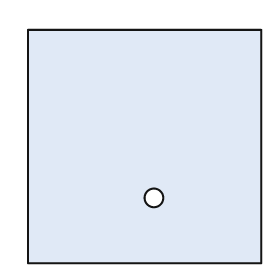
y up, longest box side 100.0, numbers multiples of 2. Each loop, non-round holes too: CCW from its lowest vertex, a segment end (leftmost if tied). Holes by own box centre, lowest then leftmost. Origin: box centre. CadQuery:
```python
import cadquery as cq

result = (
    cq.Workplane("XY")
    .moveTo(-50.0, -50.0)
    .lineTo(50.0, -50.0)
    .lineTo(50.0, 50.0)
    .lineTo(-50.0, 50.0)
    .close()
    .moveTo(4.0, -22.0)
    .circle(4.0)
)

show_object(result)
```